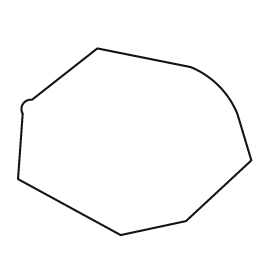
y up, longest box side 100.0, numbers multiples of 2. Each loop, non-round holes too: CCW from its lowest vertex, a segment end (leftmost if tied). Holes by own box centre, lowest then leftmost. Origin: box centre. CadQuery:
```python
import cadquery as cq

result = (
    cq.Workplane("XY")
    .moveTo(-6.0, -40.0)
    .lineTo(22.0, -34.0)
    .lineTo(50.0, -8.0)
    .lineTo(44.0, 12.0)
    .threePointArc((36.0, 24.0), (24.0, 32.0))
    .lineTo(-16.0, 40.0)
    .lineTo(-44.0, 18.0)
    .threePointArc((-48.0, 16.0), (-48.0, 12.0))
    .lineTo(-50.0, -16.0)
    .close()
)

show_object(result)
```